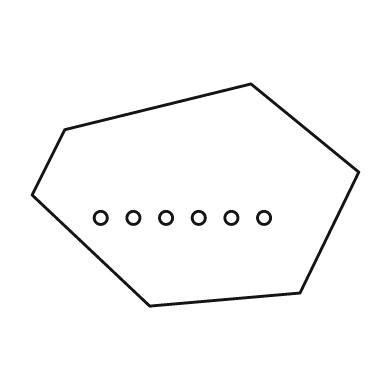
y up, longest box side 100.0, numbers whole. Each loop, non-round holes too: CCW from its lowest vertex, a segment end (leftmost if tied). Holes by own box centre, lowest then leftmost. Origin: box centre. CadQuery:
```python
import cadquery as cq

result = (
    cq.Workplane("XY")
    .moveTo(-14.0, -34.0)
    .lineTo(32.0, -30.0)
    .lineTo(50.0, 7.0)
    .lineTo(17.0, 34.0)
    .lineTo(-40.0, 20.0)
    .lineTo(-50.0, 0.0)
    .close()
    .moveTo(-29.0, -7.0)
    .circle(2.0)
    .moveTo(-19.0, -7.0)
    .circle(2.0)
    .moveTo(-9.0, -7.0)
    .circle(2.0)
    .moveTo(1.0, -7.0)
    .circle(2.0)
    .moveTo(11.0, -7.0)
    .circle(2.0)
    .moveTo(21.0, -7.0)
    .circle(2.0)
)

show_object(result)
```